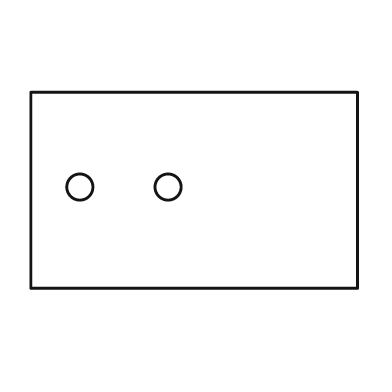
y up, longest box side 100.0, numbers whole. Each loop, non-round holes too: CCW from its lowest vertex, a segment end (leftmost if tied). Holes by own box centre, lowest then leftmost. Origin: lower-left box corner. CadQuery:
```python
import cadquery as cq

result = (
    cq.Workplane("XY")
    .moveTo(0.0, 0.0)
    .lineTo(100.0, 0.0)
    .lineTo(100.0, 60.0)
    .lineTo(0.0, 60.0)
    .close()
    .moveTo(15.0, 31.0)
    .circle(4.0)
    .moveTo(42.0, 31.0)
    .circle(4.0)
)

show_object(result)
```